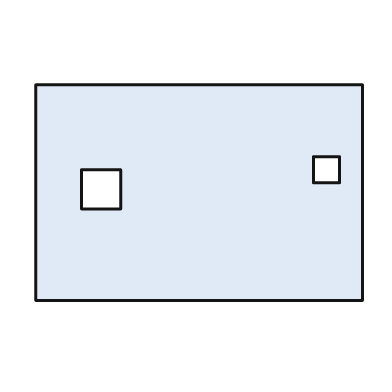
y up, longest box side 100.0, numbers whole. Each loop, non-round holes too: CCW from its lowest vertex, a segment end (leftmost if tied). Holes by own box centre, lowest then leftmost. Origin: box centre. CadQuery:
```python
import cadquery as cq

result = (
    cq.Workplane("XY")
    .moveTo(-50.0, -33.0)
    .lineTo(50.0, -33.0)
    .lineTo(50.0, 33.0)
    .lineTo(-50.0, 33.0)
    .close()
    .moveTo(-36.0, -5.0)
    .lineTo(-24.0, -5.0)
    .lineTo(-24.0, 7.0)
    .lineTo(-36.0, 7.0)
    .close()
    .moveTo(35.0, 3.0)
    .lineTo(43.0, 3.0)
    .lineTo(43.0, 11.0)
    .lineTo(35.0, 11.0)
    .close()
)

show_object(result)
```